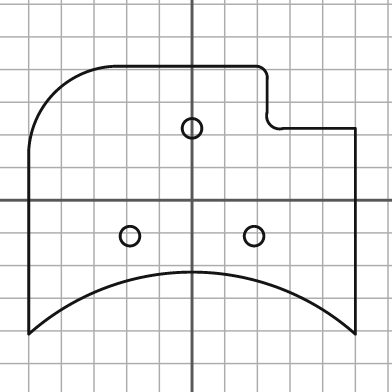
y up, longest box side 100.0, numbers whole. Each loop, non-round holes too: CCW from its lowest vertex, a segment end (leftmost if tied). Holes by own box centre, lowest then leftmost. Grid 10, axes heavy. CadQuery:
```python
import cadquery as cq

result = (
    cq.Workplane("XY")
    .moveTo(-50.0, -41.0)
    .threePointArc((0.0, -22.0), (50.0, -41.0))
    .lineTo(50.0, 22.0)
    .lineTo(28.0, 22.0)
    .threePointArc((24.0, 23.0), (23.0, 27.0))
    .lineTo(23.0, 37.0)
    .threePointArc((22.0, 40.0), (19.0, 41.0))
    .lineTo(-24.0, 41.0)
    .threePointArc((-42.0, 33.0), (-50.0, 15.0))
    .close()
    .moveTo(-19.0, -11.0)
    .circle(3.0)
    .moveTo(19.0, -11.0)
    .circle(3.0)
    .moveTo(0.0, 22.0)
    .circle(3.0)
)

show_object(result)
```